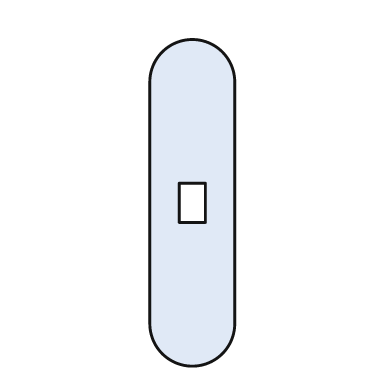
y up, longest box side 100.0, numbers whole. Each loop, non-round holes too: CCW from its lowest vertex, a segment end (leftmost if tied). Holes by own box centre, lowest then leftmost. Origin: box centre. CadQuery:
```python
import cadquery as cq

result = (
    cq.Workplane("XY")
    .moveTo(-13.0, -37.0)
    .threePointArc((0.0, -50.0), (13.0, -37.0))
    .lineTo(13.0, 37.0)
    .threePointArc((0.0, 50.0), (-13.0, 37.0))
    .close()
    .moveTo(-4.0, -6.0)
    .lineTo(4.0, -6.0)
    .lineTo(4.0, 6.0)
    .lineTo(-4.0, 6.0)
    .close()
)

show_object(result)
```